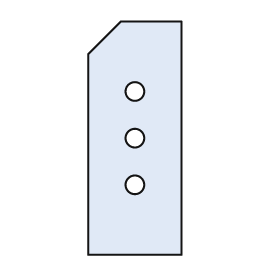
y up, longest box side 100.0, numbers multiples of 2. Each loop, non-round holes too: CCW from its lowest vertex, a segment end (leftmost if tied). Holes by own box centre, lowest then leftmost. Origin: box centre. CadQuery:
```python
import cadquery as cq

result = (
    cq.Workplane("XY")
    .moveTo(-20.0, -50.0)
    .lineTo(20.0, -50.0)
    .lineTo(20.0, 50.0)
    .lineTo(-6.0, 50.0)
    .lineTo(-20.0, 36.0)
    .close()
    .moveTo(0.0, -20.0)
    .circle(4.0)
    .moveTo(0.0, 0.0)
    .circle(4.0)
    .moveTo(0.0, 20.0)
    .circle(4.0)
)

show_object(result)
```